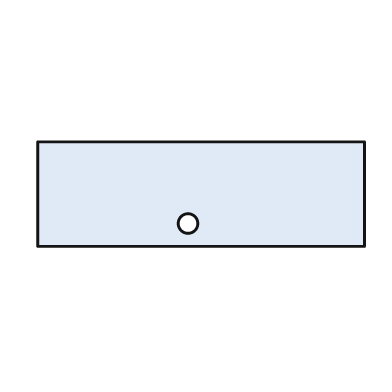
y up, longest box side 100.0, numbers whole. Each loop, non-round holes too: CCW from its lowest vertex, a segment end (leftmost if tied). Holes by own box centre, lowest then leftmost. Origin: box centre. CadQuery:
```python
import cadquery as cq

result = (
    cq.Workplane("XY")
    .moveTo(-50.0, -16.0)
    .lineTo(50.0, -16.0)
    .lineTo(50.0, 16.0)
    .lineTo(-50.0, 16.0)
    .close()
    .moveTo(-4.0, -9.0)
    .circle(3.0)
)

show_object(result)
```